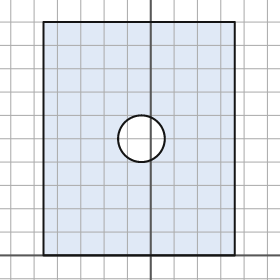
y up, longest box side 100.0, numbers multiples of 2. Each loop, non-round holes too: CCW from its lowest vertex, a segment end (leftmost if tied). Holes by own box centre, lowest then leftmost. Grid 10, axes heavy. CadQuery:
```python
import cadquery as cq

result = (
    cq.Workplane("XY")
    .moveTo(-46.0, 0.0)
    .lineTo(36.0, 0.0)
    .lineTo(36.0, 100.0)
    .lineTo(-46.0, 100.0)
    .close()
    .moveTo(-4.0, 50.0)
    .circle(10.0)
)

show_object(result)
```